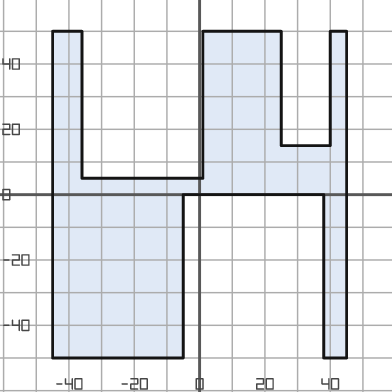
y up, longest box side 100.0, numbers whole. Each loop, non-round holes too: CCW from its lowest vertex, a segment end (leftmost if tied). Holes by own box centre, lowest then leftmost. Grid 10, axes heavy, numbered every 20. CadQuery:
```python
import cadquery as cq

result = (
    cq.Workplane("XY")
    .moveTo(-45.0, -50.0)
    .lineTo(-5.0, -50.0)
    .lineTo(-5.0, 0.0)
    .lineTo(38.0, 0.0)
    .lineTo(38.0, -50.0)
    .lineTo(45.0, -50.0)
    .lineTo(45.0, 50.0)
    .lineTo(40.0, 50.0)
    .lineTo(40.0, 15.0)
    .lineTo(25.0, 15.0)
    .lineTo(25.0, 50.0)
    .lineTo(1.0, 50.0)
    .lineTo(1.0, 5.0)
    .lineTo(-36.0, 5.0)
    .lineTo(-36.0, 50.0)
    .lineTo(-45.0, 50.0)
    .close()
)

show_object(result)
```